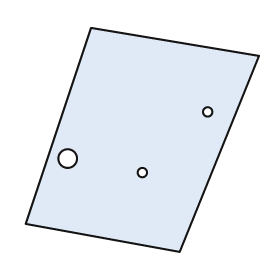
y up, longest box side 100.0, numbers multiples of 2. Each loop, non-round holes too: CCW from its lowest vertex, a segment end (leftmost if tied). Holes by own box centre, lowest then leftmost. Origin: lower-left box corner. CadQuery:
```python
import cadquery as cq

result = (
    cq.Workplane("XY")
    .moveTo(66.0, 0.0)
    .lineTo(100.0, 84.0)
    .lineTo(28.0, 96.0)
    .lineTo(0.0, 12.0)
    .close()
    .moveTo(50.0, 34.0)
    .circle(2.0)
    .moveTo(18.0, 40.0)
    .circle(4.0)
    .moveTo(78.0, 60.0)
    .circle(2.0)
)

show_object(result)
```